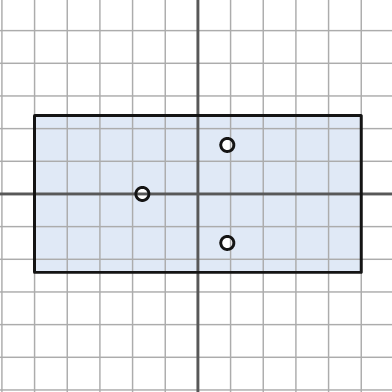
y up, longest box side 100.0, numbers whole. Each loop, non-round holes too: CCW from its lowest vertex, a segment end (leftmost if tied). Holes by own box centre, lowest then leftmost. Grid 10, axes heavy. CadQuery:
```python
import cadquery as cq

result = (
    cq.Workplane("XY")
    .moveTo(-50.0, -24.0)
    .lineTo(50.0, -24.0)
    .lineTo(50.0, 24.0)
    .lineTo(-50.0, 24.0)
    .close()
    .moveTo(9.0, -15.0)
    .circle(2.0)
    .moveTo(-17.0, 0.0)
    .circle(2.0)
    .moveTo(9.0, 15.0)
    .circle(2.0)
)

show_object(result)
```